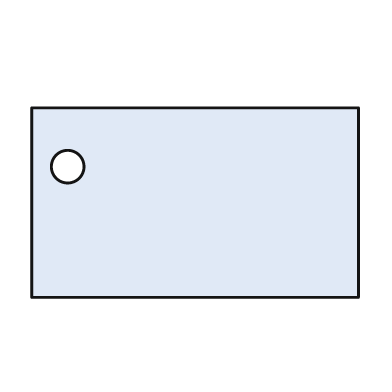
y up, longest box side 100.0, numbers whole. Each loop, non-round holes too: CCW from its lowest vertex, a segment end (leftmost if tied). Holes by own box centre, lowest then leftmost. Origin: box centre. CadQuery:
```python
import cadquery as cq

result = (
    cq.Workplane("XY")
    .moveTo(-50.0, -29.0)
    .lineTo(50.0, -29.0)
    .lineTo(50.0, 29.0)
    .lineTo(-50.0, 29.0)
    .close()
    .moveTo(-39.0, 11.0)
    .circle(5.0)
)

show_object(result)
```